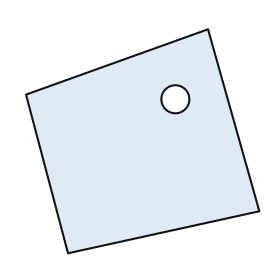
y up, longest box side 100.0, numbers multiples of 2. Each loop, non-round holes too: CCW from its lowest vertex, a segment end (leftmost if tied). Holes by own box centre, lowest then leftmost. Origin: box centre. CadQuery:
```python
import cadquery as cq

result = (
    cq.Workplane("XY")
    .moveTo(-32.0, -48.0)
    .lineTo(50.0, -30.0)
    .lineTo(28.0, 48.0)
    .lineTo(-50.0, 20.0)
    .close()
    .moveTo(14.0, 18.0)
    .circle(6.0)
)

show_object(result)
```